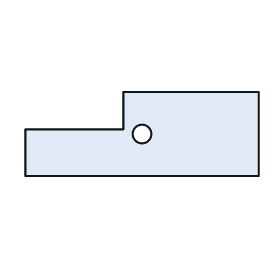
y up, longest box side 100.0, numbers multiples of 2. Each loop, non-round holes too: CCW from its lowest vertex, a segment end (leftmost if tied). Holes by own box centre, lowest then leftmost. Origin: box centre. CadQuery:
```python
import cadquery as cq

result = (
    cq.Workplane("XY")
    .moveTo(-50.0, -18.0)
    .lineTo(50.0, -18.0)
    .lineTo(50.0, 18.0)
    .lineTo(-8.0, 18.0)
    .lineTo(-8.0, 2.0)
    .lineTo(-50.0, 2.0)
    .close()
    .moveTo(0.0, 0.0)
    .circle(4.0)
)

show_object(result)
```